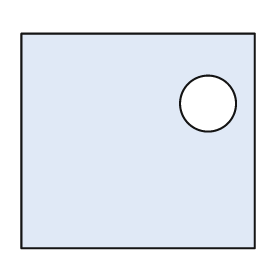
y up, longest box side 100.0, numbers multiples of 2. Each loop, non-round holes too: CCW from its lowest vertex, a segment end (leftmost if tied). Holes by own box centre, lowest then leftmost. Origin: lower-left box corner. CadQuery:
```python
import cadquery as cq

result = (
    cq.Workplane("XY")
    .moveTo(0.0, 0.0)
    .lineTo(100.0, 0.0)
    .lineTo(100.0, 92.0)
    .lineTo(0.0, 92.0)
    .close()
    .moveTo(80.0, 62.0)
    .circle(12.0)
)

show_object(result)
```